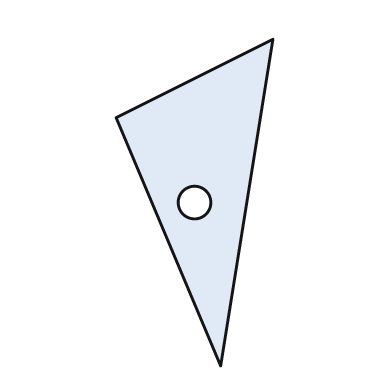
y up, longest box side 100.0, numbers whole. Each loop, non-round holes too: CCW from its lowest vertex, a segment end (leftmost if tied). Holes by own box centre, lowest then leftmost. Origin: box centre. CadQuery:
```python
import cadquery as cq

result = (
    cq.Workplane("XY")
    .moveTo(8.0, -50.0)
    .lineTo(24.0, 50.0)
    .lineTo(-24.0, 26.0)
    .close()
    .moveTo(0.0, 0.0)
    .circle(5.0)
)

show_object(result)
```